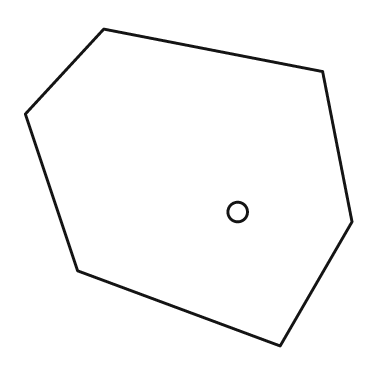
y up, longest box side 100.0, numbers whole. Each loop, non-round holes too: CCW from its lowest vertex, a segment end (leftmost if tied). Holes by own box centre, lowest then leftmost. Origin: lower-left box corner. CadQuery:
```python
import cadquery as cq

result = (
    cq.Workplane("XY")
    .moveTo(78.0, 0.0)
    .lineTo(100.0, 38.0)
    .lineTo(91.0, 84.0)
    .lineTo(24.0, 97.0)
    .lineTo(0.0, 71.0)
    .lineTo(16.0, 23.0)
    .close()
    .moveTo(65.0, 41.0)
    .circle(3.0)
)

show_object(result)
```